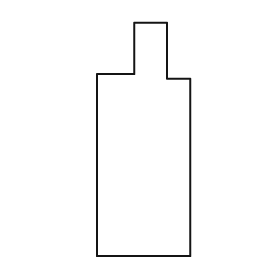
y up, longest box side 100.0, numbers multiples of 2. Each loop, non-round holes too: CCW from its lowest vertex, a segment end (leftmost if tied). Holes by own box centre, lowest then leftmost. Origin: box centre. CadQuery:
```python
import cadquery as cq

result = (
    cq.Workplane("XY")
    .moveTo(-20.0, -50.0)
    .lineTo(20.0, -50.0)
    .lineTo(20.0, 26.0)
    .lineTo(10.0, 26.0)
    .lineTo(10.0, 50.0)
    .lineTo(-4.0, 50.0)
    .lineTo(-4.0, 28.0)
    .lineTo(-20.0, 28.0)
    .close()
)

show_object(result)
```